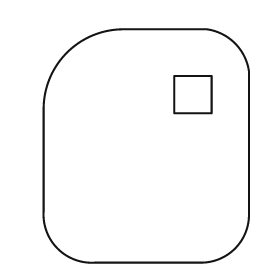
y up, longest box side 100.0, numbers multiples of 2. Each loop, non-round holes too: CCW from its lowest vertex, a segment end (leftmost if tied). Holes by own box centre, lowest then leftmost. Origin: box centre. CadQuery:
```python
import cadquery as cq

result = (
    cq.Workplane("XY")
    .moveTo(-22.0, -50.0)
    .lineTo(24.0, -50.0)
    .threePointArc((38.0, -44.0), (44.0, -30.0))
    .lineTo(44.0, 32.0)
    .threePointArc((38.0, 44.0), (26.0, 50.0))
    .lineTo(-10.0, 50.0)
    .threePointArc((-34.0, 40.0), (-44.0, 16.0))
    .lineTo(-44.0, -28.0)
    .threePointArc((-38.0, -44.0), (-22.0, -50.0))
    .close()
    .moveTo(12.0, 14.0)
    .lineTo(28.0, 14.0)
    .lineTo(28.0, 30.0)
    .lineTo(12.0, 30.0)
    .close()
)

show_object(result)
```